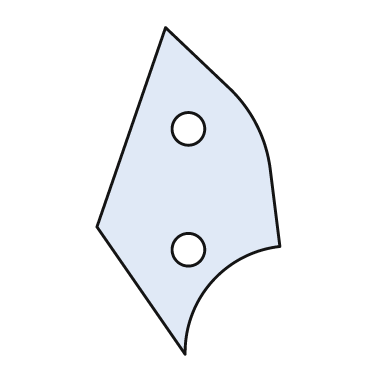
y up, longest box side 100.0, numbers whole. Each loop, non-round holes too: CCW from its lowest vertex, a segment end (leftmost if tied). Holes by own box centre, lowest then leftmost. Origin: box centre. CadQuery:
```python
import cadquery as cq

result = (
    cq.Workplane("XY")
    .moveTo(-1.0, -50.0)
    .threePointArc((7.0, -28.0), (28.0, -17.0))
    .lineTo(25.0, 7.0)
    .threePointArc((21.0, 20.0), (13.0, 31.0))
    .lineTo(-7.0, 50.0)
    .lineTo(-28.0, -11.0)
    .close()
    .moveTo(0.0, -18.0)
    .circle(5.0)
    .moveTo(0.0, 19.0)
    .circle(5.0)
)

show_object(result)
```